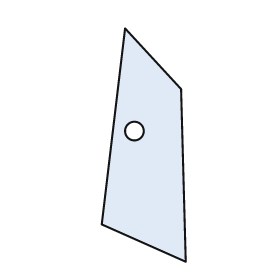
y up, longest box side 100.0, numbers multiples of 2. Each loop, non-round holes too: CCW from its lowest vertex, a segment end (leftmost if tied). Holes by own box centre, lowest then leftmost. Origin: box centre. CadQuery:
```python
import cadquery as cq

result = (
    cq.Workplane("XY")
    .moveTo(18.0, -50.0)
    .lineTo(16.0, 24.0)
    .lineTo(-8.0, 50.0)
    .lineTo(-18.0, -34.0)
    .close()
    .moveTo(-4.0, 6.0)
    .circle(4.0)
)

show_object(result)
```